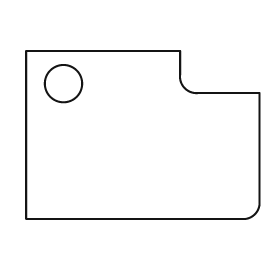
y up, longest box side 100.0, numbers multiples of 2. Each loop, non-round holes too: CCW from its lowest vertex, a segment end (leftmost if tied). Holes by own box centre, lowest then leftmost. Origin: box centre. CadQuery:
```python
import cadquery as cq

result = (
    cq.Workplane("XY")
    .moveTo(-50.0, -36.0)
    .lineTo(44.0, -36.0)
    .threePointArc((48.0, -34.0), (50.0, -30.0))
    .lineTo(50.0, 18.0)
    .lineTo(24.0, 18.0)
    .threePointArc((18.0, 20.0), (16.0, 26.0))
    .lineTo(16.0, 36.0)
    .lineTo(-50.0, 36.0)
    .close()
    .moveTo(-34.0, 22.0)
    .circle(8.0)
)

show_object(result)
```